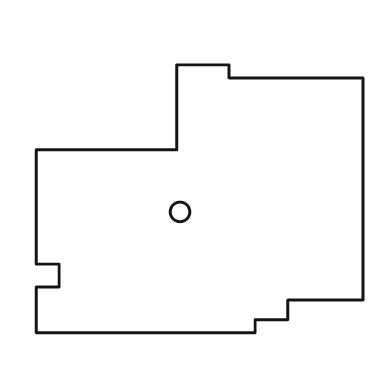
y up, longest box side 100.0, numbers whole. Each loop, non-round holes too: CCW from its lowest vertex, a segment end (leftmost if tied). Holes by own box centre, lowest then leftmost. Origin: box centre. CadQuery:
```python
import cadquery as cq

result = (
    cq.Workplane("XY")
    .moveTo(-50.0, -41.0)
    .lineTo(17.0, -41.0)
    .lineTo(17.0, -37.0)
    .lineTo(27.0, -37.0)
    .lineTo(27.0, -31.0)
    .lineTo(50.0, -31.0)
    .lineTo(50.0, 37.0)
    .lineTo(9.0, 37.0)
    .lineTo(9.0, 41.0)
    .lineTo(-7.0, 41.0)
    .lineTo(-7.0, 15.0)
    .lineTo(-50.0, 15.0)
    .lineTo(-50.0, -20.0)
    .lineTo(-43.0, -20.0)
    .lineTo(-43.0, -27.0)
    .lineTo(-50.0, -27.0)
    .close()
    .moveTo(-6.0, -4.0)
    .circle(3.0)
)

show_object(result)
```